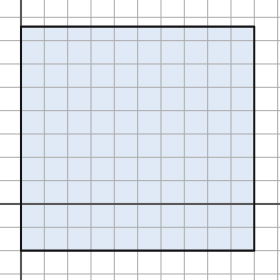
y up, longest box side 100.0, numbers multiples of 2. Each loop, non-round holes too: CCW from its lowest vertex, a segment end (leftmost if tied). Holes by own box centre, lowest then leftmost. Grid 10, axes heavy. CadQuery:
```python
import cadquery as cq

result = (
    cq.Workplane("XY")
    .moveTo(0.0, -20.0)
    .lineTo(100.0, -20.0)
    .lineTo(100.0, 76.0)
    .lineTo(0.0, 76.0)
    .close()
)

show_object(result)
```